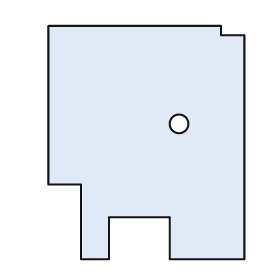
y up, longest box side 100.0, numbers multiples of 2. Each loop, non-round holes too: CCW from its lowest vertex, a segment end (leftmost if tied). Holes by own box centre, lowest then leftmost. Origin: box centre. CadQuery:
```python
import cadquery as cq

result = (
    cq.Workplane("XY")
    .moveTo(-28.0, -50.0)
    .lineTo(-16.0, -50.0)
    .lineTo(-16.0, -32.0)
    .lineTo(10.0, -32.0)
    .lineTo(10.0, -50.0)
    .lineTo(42.0, -50.0)
    .lineTo(42.0, 46.0)
    .lineTo(32.0, 46.0)
    .lineTo(32.0, 50.0)
    .lineTo(-42.0, 50.0)
    .lineTo(-42.0, -18.0)
    .lineTo(-28.0, -18.0)
    .close()
    .moveTo(14.0, 8.0)
    .circle(4.0)
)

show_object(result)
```